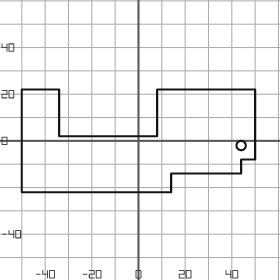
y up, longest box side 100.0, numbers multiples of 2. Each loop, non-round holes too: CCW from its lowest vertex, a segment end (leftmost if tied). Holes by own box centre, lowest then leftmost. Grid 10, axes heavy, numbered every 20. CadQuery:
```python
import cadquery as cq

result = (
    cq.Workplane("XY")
    .moveTo(-50.0, -22.0)
    .lineTo(14.0, -22.0)
    .lineTo(14.0, -14.0)
    .lineTo(44.0, -14.0)
    .lineTo(44.0, -8.0)
    .lineTo(50.0, -8.0)
    .lineTo(50.0, 22.0)
    .lineTo(8.0, 22.0)
    .lineTo(8.0, 2.0)
    .lineTo(-34.0, 2.0)
    .lineTo(-34.0, 22.0)
    .lineTo(-50.0, 22.0)
    .close()
    .moveTo(44.0, -2.0)
    .circle(2.0)
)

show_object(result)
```